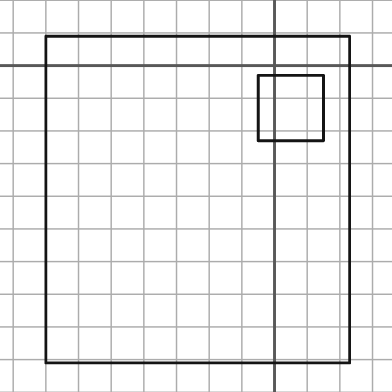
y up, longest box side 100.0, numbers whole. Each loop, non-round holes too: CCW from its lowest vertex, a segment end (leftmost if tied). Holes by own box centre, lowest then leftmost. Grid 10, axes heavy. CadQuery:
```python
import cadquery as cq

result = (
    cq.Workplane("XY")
    .moveTo(-70.0, -91.0)
    .lineTo(23.0, -91.0)
    .lineTo(23.0, 9.0)
    .lineTo(-70.0, 9.0)
    .close()
    .moveTo(-5.0, -23.0)
    .lineTo(15.0, -23.0)
    .lineTo(15.0, -3.0)
    .lineTo(-5.0, -3.0)
    .close()
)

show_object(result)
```